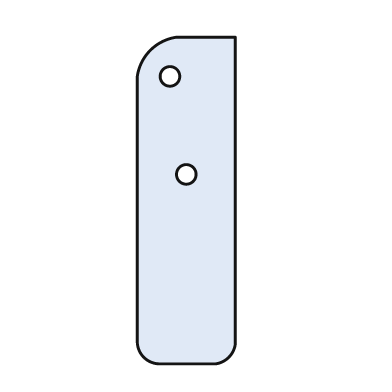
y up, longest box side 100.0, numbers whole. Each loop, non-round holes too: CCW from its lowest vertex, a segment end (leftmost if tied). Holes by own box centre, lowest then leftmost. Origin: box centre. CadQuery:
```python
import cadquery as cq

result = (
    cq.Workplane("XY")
    .moveTo(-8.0, -50.0)
    .lineTo(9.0, -50.0)
    .threePointArc((13.0, -48.0), (15.0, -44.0))
    .lineTo(15.0, 50.0)
    .lineTo(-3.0, 50.0)
    .threePointArc((-11.0, 46.0), (-15.0, 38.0))
    .lineTo(-15.0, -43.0)
    .threePointArc((-13.0, -48.0), (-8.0, -50.0))
    .close()
    .moveTo(0.0, 8.0)
    .circle(3.0)
    .moveTo(-5.0, 38.0)
    .circle(3.0)
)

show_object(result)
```